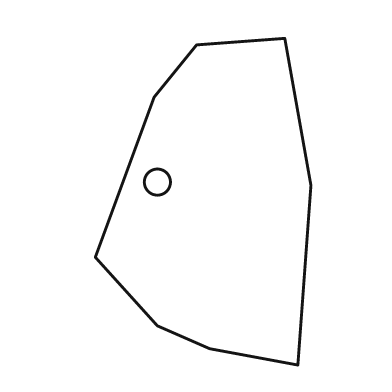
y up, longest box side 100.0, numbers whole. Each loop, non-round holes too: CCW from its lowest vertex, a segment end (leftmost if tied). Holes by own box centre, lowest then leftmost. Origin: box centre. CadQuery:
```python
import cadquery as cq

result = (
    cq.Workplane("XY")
    .moveTo(29.0, -50.0)
    .lineTo(33.0, 5.0)
    .lineTo(25.0, 50.0)
    .lineTo(-2.0, 48.0)
    .lineTo(-15.0, 32.0)
    .lineTo(-33.0, -17.0)
    .lineTo(-14.0, -38.0)
    .lineTo(2.0, -45.0)
    .close()
    .moveTo(-14.0, 6.0)
    .circle(4.0)
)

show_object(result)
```